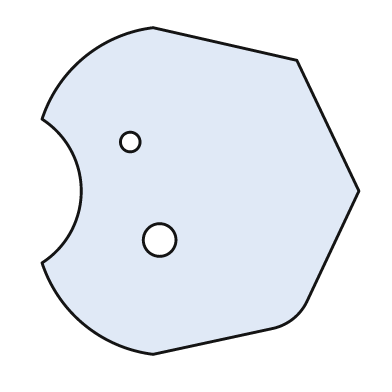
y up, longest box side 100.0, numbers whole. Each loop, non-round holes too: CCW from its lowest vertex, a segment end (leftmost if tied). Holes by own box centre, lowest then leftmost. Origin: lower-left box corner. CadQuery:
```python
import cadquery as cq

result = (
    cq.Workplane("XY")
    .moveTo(34.0, 0.0)
    .lineTo(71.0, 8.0)
    .threePointArc((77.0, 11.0), (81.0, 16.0))
    .lineTo(97.0, 50.0)
    .lineTo(78.0, 90.0)
    .lineTo(34.0, 100.0)
    .threePointArc((13.0, 91.0), (0.0, 72.0))
    .threePointArc((12.0, 50.0), (0.0, 28.0))
    .threePointArc((13.0, 9.0), (34.0, 0.0))
    .close()
    .moveTo(36.0, 35.0)
    .circle(5.0)
    .moveTo(27.0, 65.0)
    .circle(3.0)
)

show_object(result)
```